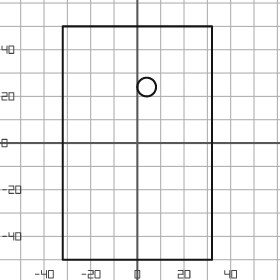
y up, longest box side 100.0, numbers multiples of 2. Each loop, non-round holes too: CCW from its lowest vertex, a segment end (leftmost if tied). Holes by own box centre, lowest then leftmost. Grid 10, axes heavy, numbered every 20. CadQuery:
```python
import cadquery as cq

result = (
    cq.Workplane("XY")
    .moveTo(-32.0, -50.0)
    .lineTo(32.0, -50.0)
    .lineTo(32.0, 50.0)
    .lineTo(-32.0, 50.0)
    .close()
    .moveTo(4.0, 24.0)
    .circle(4.0)
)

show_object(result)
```